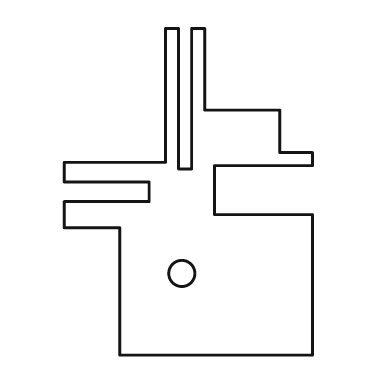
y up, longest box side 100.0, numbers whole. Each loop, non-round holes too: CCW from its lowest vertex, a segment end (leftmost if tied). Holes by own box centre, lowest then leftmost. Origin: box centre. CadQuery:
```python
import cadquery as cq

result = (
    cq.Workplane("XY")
    .moveTo(-21.0, -50.0)
    .lineTo(38.0, -50.0)
    .lineTo(38.0, -7.0)
    .lineTo(8.0, -7.0)
    .lineTo(8.0, 8.0)
    .lineTo(38.0, 8.0)
    .lineTo(38.0, 12.0)
    .lineTo(28.0, 12.0)
    .lineTo(28.0, 25.0)
    .lineTo(5.0, 25.0)
    .lineTo(5.0, 50.0)
    .lineTo(1.0, 50.0)
    .lineTo(1.0, 7.0)
    .lineTo(-3.0, 7.0)
    .lineTo(-3.0, 50.0)
    .lineTo(-7.0, 50.0)
    .lineTo(-7.0, 9.0)
    .lineTo(-38.0, 9.0)
    .lineTo(-38.0, 3.0)
    .lineTo(-12.0, 3.0)
    .lineTo(-12.0, -3.0)
    .lineTo(-38.0, -3.0)
    .lineTo(-38.0, -11.0)
    .lineTo(-21.0, -11.0)
    .close()
    .moveTo(-2.0, -25.0)
    .circle(4.0)
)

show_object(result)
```